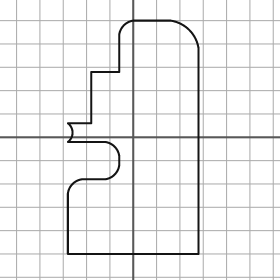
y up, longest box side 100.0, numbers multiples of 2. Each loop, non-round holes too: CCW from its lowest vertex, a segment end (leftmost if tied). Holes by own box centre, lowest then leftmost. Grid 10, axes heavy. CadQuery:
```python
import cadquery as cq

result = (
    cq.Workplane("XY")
    .moveTo(-28.0, -50.0)
    .lineTo(28.0, -50.0)
    .lineTo(28.0, 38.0)
    .threePointArc((24.0, 46.0), (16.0, 50.0))
    .lineTo(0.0, 50.0)
    .threePointArc((-4.0, 48.0), (-6.0, 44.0))
    .lineTo(-6.0, 28.0)
    .lineTo(-18.0, 28.0)
    .lineTo(-18.0, 6.0)
    .lineTo(-28.0, 6.0)
    .threePointArc((-26.0, 2.0), (-28.0, -2.0))
    .lineTo(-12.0, -2.0)
    .threePointArc((-8.0, -4.0), (-6.0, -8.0))
    .lineTo(-6.0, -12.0)
    .threePointArc((-8.0, -16.0), (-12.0, -18.0))
    .lineTo(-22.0, -18.0)
    .threePointArc((-26.0, -20.0), (-28.0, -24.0))
    .close()
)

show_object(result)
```